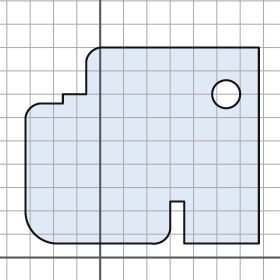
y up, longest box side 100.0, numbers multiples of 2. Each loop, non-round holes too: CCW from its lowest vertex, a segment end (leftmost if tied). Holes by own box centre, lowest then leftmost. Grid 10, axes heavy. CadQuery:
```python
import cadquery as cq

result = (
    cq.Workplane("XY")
    .moveTo(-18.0, 6.0)
    .lineTo(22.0, 6.0)
    .threePointArc((28.0, 8.0), (30.0, 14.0))
    .lineTo(30.0, 24.0)
    .lineTo(36.0, 24.0)
    .lineTo(36.0, 6.0)
    .lineTo(68.0, 6.0)
    .lineTo(68.0, 90.0)
    .lineTo(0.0, 90.0)
    .threePointArc((-4.0, 88.0), (-6.0, 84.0))
    .lineTo(-6.0, 70.0)
    .lineTo(-16.0, 70.0)
    .lineTo(-16.0, 66.0)
    .lineTo(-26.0, 66.0)
    .threePointArc((-30.0, 64.0), (-32.0, 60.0))
    .lineTo(-32.0, 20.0)
    .threePointArc((-28.0, 10.0), (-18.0, 6.0))
    .close()
    .moveTo(54.0, 70.0)
    .circle(6.0)
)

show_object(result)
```